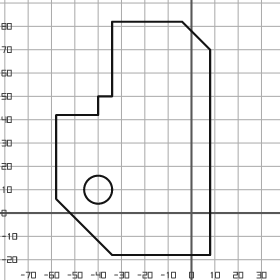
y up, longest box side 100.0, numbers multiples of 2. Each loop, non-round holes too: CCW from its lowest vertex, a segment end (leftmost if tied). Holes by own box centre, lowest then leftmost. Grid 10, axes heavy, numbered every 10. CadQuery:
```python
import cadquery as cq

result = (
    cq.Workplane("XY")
    .moveTo(-34.0, -18.0)
    .lineTo(8.0, -18.0)
    .lineTo(8.0, 70.0)
    .lineTo(-4.0, 82.0)
    .lineTo(-34.0, 82.0)
    .lineTo(-34.0, 50.0)
    .lineTo(-40.0, 50.0)
    .lineTo(-40.0, 42.0)
    .lineTo(-58.0, 42.0)
    .lineTo(-58.0, 6.0)
    .close()
    .moveTo(-40.0, 10.0)
    .circle(6.0)
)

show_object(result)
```